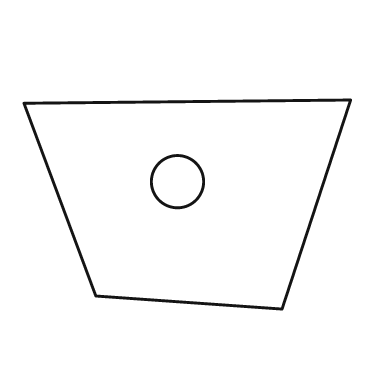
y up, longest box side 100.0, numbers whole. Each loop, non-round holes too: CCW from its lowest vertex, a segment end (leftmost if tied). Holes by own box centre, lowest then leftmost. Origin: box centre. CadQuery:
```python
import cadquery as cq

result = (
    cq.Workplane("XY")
    .moveTo(29.0, -32.0)
    .lineTo(50.0, 32.0)
    .lineTo(-50.0, 31.0)
    .lineTo(-28.0, -28.0)
    .close()
    .moveTo(-3.0, 7.0)
    .circle(8.0)
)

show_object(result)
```